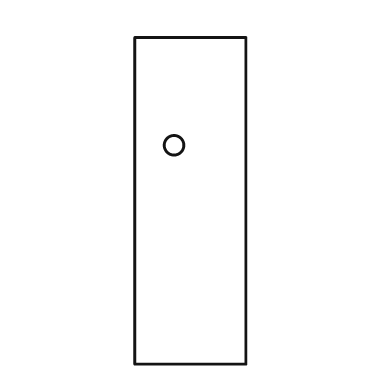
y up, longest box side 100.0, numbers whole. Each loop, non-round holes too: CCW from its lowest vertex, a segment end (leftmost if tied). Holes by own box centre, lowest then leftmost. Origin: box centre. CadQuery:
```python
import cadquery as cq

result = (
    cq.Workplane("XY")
    .moveTo(-17.0, -50.0)
    .lineTo(17.0, -50.0)
    .lineTo(17.0, 50.0)
    .lineTo(-17.0, 50.0)
    .close()
    .moveTo(-5.0, 17.0)
    .circle(3.0)
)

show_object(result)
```